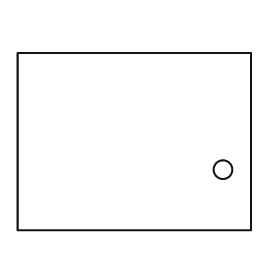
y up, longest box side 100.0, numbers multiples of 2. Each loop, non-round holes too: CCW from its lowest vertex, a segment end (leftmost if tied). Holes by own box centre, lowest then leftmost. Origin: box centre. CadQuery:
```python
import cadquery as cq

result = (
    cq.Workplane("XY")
    .moveTo(-50.0, -38.0)
    .lineTo(50.0, -38.0)
    .lineTo(50.0, 38.0)
    .lineTo(-50.0, 38.0)
    .close()
    .moveTo(38.0, -12.0)
    .circle(4.0)
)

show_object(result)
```